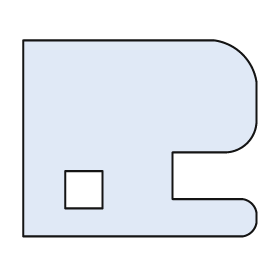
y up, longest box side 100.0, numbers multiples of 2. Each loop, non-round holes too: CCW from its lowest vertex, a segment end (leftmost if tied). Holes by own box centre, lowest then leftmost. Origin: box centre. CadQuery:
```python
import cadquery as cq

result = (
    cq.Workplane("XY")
    .moveTo(-50.0, -42.0)
    .lineTo(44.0, -42.0)
    .threePointArc((48.0, -40.0), (50.0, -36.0))
    .lineTo(50.0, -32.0)
    .threePointArc((48.0, -28.0), (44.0, -26.0))
    .lineTo(14.0, -26.0)
    .lineTo(14.0, -6.0)
    .lineTo(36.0, -6.0)
    .threePointArc((46.0, -2.0), (50.0, 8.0))
    .lineTo(50.0, 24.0)
    .threePointArc((44.0, 36.0), (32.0, 42.0))
    .lineTo(-50.0, 42.0)
    .close()
    .moveTo(-32.0, -30.0)
    .lineTo(-16.0, -30.0)
    .lineTo(-16.0, -14.0)
    .lineTo(-32.0, -14.0)
    .close()
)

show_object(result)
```